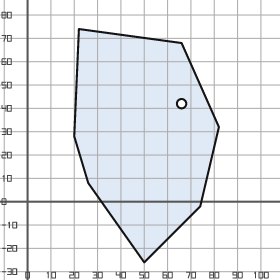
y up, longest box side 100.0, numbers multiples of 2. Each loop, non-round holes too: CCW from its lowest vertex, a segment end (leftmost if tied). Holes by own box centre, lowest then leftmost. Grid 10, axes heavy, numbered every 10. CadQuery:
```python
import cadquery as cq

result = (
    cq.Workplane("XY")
    .moveTo(50.0, -26.0)
    .lineTo(74.0, -2.0)
    .lineTo(82.0, 32.0)
    .lineTo(66.0, 68.0)
    .lineTo(22.0, 74.0)
    .lineTo(20.0, 28.0)
    .lineTo(26.0, 8.0)
    .close()
    .moveTo(66.0, 42.0)
    .circle(2.0)
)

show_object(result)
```